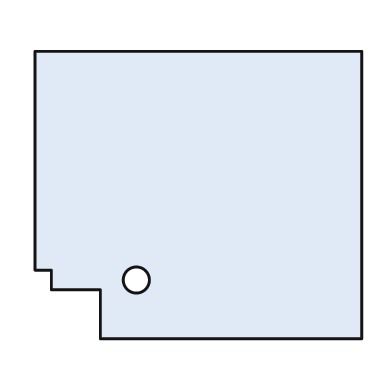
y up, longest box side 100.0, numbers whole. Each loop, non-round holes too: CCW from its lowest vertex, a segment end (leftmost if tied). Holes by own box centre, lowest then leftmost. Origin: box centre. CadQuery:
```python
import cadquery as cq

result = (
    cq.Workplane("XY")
    .moveTo(-30.0, -44.0)
    .lineTo(50.0, -44.0)
    .lineTo(50.0, 44.0)
    .lineTo(-50.0, 44.0)
    .lineTo(-50.0, -23.0)
    .lineTo(-45.0, -23.0)
    .lineTo(-45.0, -29.0)
    .lineTo(-30.0, -29.0)
    .close()
    .moveTo(-19.0, -26.0)
    .circle(4.0)
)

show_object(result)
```